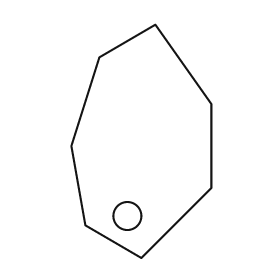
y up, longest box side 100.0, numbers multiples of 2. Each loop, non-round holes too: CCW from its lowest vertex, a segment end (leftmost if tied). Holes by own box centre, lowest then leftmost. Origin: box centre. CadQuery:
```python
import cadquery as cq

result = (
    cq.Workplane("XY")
    .moveTo(0.0, -50.0)
    .lineTo(30.0, -20.0)
    .lineTo(30.0, 16.0)
    .lineTo(6.0, 50.0)
    .lineTo(-18.0, 36.0)
    .lineTo(-30.0, -2.0)
    .lineTo(-24.0, -36.0)
    .close()
    .moveTo(-6.0, -32.0)
    .circle(6.0)
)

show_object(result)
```